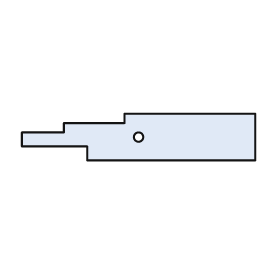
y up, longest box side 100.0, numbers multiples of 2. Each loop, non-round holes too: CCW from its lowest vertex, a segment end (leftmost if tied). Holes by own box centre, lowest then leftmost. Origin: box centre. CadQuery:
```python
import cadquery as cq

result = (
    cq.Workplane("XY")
    .moveTo(-22.0, -10.0)
    .lineTo(50.0, -10.0)
    .lineTo(50.0, 10.0)
    .lineTo(-6.0, 10.0)
    .lineTo(-6.0, 6.0)
    .lineTo(-32.0, 6.0)
    .lineTo(-32.0, 2.0)
    .lineTo(-50.0, 2.0)
    .lineTo(-50.0, -4.0)
    .lineTo(-22.0, -4.0)
    .close()
    .moveTo(0.0, 0.0)
    .circle(2.0)
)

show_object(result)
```